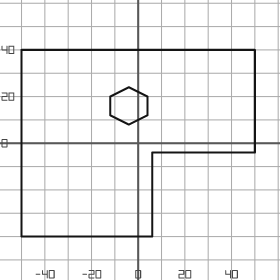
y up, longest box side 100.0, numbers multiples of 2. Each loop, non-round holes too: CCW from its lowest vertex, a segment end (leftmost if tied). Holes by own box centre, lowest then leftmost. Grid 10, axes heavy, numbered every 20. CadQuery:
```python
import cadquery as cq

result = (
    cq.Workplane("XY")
    .moveTo(-50.0, -40.0)
    .lineTo(6.0, -40.0)
    .lineTo(6.0, -4.0)
    .lineTo(50.0, -4.0)
    .lineTo(50.0, 40.0)
    .lineTo(-50.0, 40.0)
    .close()
    .moveTo(-4.0, 8.0)
    .lineTo(4.0, 12.0)
    .lineTo(4.0, 20.0)
    .lineTo(-4.0, 24.0)
    .lineTo(-12.0, 20.0)
    .lineTo(-12.0, 12.0)
    .close()
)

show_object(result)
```